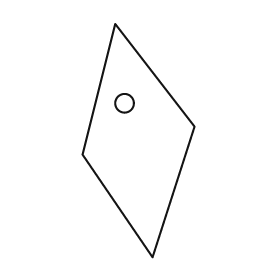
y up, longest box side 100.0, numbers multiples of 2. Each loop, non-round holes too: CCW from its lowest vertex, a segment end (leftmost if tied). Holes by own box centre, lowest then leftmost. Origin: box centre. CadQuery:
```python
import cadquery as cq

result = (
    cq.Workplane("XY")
    .moveTo(6.0, -50.0)
    .lineTo(24.0, 6.0)
    .lineTo(-10.0, 50.0)
    .lineTo(-24.0, -6.0)
    .close()
    .moveTo(-6.0, 16.0)
    .circle(4.0)
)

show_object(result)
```